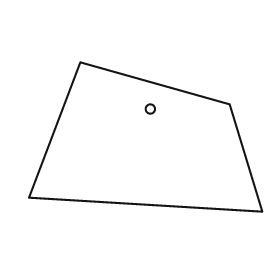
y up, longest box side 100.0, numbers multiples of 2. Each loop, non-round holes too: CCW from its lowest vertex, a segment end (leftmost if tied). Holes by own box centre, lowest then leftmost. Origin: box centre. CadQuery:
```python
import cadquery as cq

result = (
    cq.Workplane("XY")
    .moveTo(50.0, -32.0)
    .lineTo(36.0, 14.0)
    .lineTo(-28.0, 32.0)
    .lineTo(-50.0, -26.0)
    .close()
    .moveTo(2.0, 12.0)
    .circle(2.0)
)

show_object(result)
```